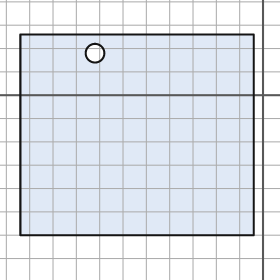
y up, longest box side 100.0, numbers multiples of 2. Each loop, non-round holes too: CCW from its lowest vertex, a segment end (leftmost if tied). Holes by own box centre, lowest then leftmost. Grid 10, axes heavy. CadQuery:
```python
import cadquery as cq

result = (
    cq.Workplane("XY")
    .moveTo(-104.0, -60.0)
    .lineTo(-4.0, -60.0)
    .lineTo(-4.0, 26.0)
    .lineTo(-104.0, 26.0)
    .close()
    .moveTo(-72.0, 18.0)
    .circle(4.0)
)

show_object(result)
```